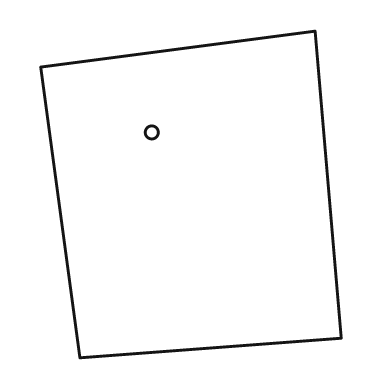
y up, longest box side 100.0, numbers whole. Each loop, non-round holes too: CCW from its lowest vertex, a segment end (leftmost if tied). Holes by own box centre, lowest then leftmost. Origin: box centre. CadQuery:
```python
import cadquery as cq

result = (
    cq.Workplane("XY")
    .moveTo(-34.0, -50.0)
    .lineTo(46.0, -44.0)
    .lineTo(38.0, 50.0)
    .lineTo(-46.0, 39.0)
    .close()
    .moveTo(-12.0, 19.0)
    .circle(2.0)
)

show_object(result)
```